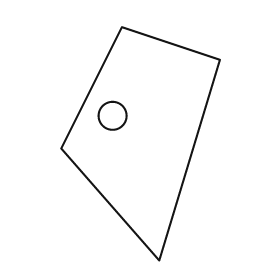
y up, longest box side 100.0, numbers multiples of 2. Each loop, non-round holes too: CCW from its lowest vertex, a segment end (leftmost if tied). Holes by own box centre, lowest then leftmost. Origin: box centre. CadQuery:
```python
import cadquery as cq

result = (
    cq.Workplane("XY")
    .moveTo(8.0, -50.0)
    .lineTo(34.0, 36.0)
    .lineTo(-8.0, 50.0)
    .lineTo(-34.0, -2.0)
    .close()
    .moveTo(-12.0, 12.0)
    .circle(6.0)
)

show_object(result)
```